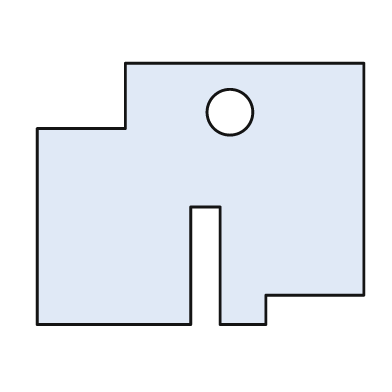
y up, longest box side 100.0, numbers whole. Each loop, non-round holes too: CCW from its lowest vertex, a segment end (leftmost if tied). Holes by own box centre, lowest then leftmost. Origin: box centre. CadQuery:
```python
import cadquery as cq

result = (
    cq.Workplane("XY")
    .moveTo(-50.0, -40.0)
    .lineTo(-3.0, -40.0)
    .lineTo(-3.0, -4.0)
    .lineTo(6.0, -4.0)
    .lineTo(6.0, -40.0)
    .lineTo(20.0, -40.0)
    .lineTo(20.0, -31.0)
    .lineTo(50.0, -31.0)
    .lineTo(50.0, 40.0)
    .lineTo(-23.0, 40.0)
    .lineTo(-23.0, 20.0)
    .lineTo(-50.0, 20.0)
    .close()
    .moveTo(9.0, 25.0)
    .circle(7.0)
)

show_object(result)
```